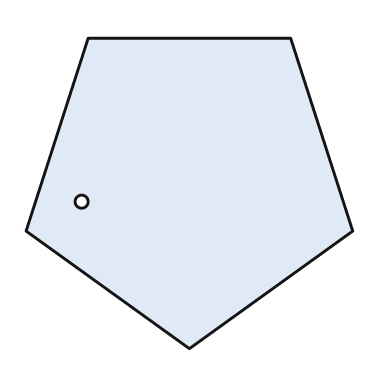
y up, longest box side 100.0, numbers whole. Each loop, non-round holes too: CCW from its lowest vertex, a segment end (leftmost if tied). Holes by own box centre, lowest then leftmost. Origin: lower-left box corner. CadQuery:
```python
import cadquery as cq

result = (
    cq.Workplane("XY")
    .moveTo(50.0, 0.0)
    .lineTo(100.0, 36.0)
    .lineTo(81.0, 95.0)
    .lineTo(19.0, 95.0)
    .lineTo(0.0, 36.0)
    .close()
    .moveTo(17.0, 45.0)
    .circle(2.0)
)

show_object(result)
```